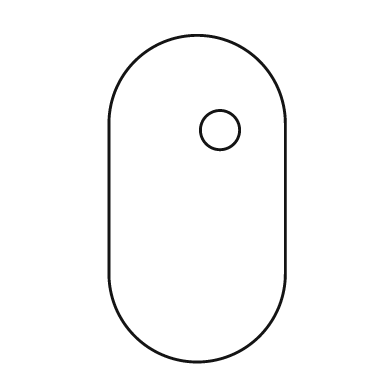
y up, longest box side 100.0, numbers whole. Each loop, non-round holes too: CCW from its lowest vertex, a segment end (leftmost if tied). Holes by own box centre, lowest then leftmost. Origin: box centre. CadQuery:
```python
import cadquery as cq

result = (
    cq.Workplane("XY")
    .moveTo(-27.0, -23.0)
    .threePointArc((0.0, -50.0), (27.0, -23.0))
    .lineTo(27.0, 23.0)
    .threePointArc((0.0, 50.0), (-27.0, 23.0))
    .close()
    .moveTo(7.0, 21.0)
    .circle(6.0)
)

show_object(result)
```